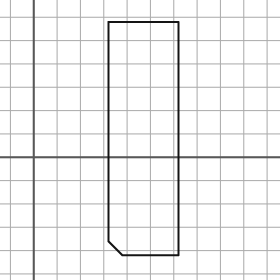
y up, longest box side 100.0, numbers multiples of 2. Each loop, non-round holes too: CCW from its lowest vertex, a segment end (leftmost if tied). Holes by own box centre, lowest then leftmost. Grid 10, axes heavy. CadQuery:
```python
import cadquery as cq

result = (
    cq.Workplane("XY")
    .moveTo(38.0, -42.0)
    .lineTo(62.0, -42.0)
    .lineTo(62.0, 58.0)
    .lineTo(32.0, 58.0)
    .lineTo(32.0, -36.0)
    .close()
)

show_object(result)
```